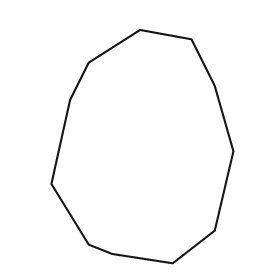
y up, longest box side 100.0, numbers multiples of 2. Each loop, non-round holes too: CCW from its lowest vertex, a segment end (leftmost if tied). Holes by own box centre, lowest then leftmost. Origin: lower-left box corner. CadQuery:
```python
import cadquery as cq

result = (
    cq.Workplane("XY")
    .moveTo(52.0, 0.0)
    .lineTo(70.0, 14.0)
    .lineTo(78.0, 48.0)
    .lineTo(70.0, 76.0)
    .lineTo(60.0, 96.0)
    .lineTo(38.0, 100.0)
    .lineTo(16.0, 86.0)
    .lineTo(8.0, 70.0)
    .lineTo(0.0, 34.0)
    .lineTo(16.0, 8.0)
    .lineTo(26.0, 4.0)
    .close()
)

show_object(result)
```